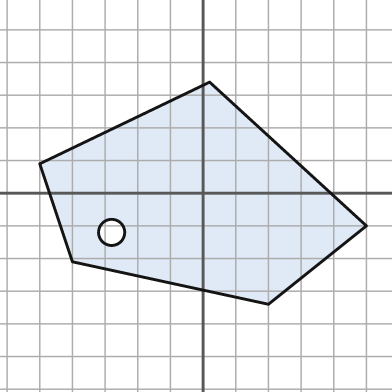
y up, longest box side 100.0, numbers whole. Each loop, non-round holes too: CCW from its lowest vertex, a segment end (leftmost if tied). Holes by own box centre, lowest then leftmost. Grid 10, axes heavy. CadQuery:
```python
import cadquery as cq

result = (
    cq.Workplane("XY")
    .moveTo(20.0, -34.0)
    .lineTo(50.0, -10.0)
    .lineTo(2.0, 34.0)
    .lineTo(-50.0, 9.0)
    .lineTo(-40.0, -21.0)
    .close()
    .moveTo(-28.0, -12.0)
    .circle(4.0)
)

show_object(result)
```